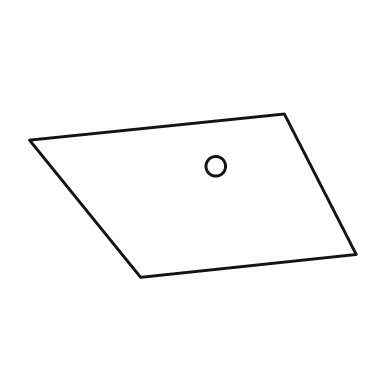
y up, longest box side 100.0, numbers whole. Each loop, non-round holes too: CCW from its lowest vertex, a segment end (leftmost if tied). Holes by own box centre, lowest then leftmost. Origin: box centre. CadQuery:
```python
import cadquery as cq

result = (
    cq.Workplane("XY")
    .moveTo(-16.0, -25.0)
    .lineTo(50.0, -18.0)
    .lineTo(28.0, 25.0)
    .lineTo(-50.0, 17.0)
    .close()
    .moveTo(7.0, 9.0)
    .circle(3.0)
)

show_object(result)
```